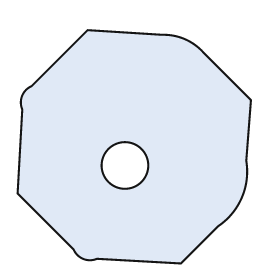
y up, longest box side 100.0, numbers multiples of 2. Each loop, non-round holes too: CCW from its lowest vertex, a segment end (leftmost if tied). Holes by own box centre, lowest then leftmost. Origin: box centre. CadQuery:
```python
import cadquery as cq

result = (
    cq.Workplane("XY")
    .moveTo(20.0, -50.0)
    .lineTo(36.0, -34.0)
    .threePointArc((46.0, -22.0), (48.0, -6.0))
    .lineTo(50.0, 20.0)
    .lineTo(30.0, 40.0)
    .threePointArc((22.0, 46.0), (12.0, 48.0))
    .lineTo(-20.0, 50.0)
    .lineTo(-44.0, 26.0)
    .threePointArc((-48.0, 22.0), (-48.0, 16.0))
    .lineTo(-50.0, -20.0)
    .lineTo(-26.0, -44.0)
    .threePointArc((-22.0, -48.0), (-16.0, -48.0))
    .close()
    .moveTo(-4.0, -8.0)
    .circle(10.0)
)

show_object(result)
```